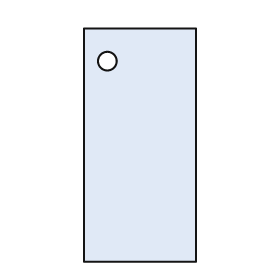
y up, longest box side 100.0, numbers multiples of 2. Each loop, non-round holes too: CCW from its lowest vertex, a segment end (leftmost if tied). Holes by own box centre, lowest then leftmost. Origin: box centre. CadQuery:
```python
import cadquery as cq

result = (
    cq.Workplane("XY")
    .moveTo(-24.0, -50.0)
    .lineTo(24.0, -50.0)
    .lineTo(24.0, 50.0)
    .lineTo(-24.0, 50.0)
    .close()
    .moveTo(-14.0, 36.0)
    .circle(4.0)
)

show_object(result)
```